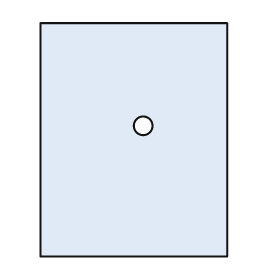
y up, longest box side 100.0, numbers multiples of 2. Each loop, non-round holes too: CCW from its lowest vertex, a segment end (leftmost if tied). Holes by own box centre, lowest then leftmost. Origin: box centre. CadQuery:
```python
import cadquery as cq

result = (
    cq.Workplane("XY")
    .moveTo(-40.0, -50.0)
    .lineTo(40.0, -50.0)
    .lineTo(40.0, 50.0)
    .lineTo(-40.0, 50.0)
    .close()
    .moveTo(4.0, 6.0)
    .circle(4.0)
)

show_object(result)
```